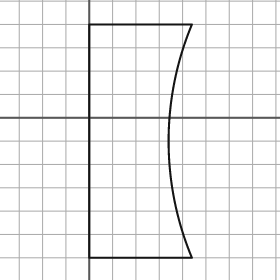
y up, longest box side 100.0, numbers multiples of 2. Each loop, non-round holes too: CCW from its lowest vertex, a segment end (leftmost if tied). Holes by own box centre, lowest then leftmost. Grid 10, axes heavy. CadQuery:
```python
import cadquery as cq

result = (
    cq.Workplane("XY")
    .moveTo(0.0, -60.0)
    .lineTo(44.0, -60.0)
    .threePointArc((34.0, -10.0), (44.0, 40.0))
    .lineTo(0.0, 40.0)
    .close()
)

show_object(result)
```